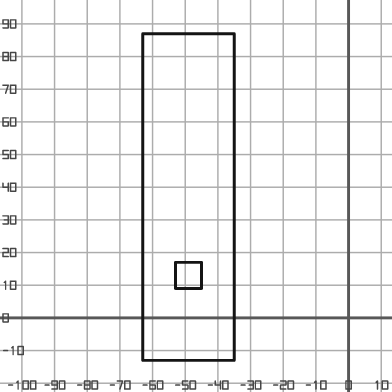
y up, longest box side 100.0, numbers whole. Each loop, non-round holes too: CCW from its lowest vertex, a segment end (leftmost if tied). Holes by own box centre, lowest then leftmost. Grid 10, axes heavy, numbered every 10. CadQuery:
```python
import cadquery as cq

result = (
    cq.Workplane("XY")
    .moveTo(-63.0, -13.0)
    .lineTo(-35.0, -13.0)
    .lineTo(-35.0, 87.0)
    .lineTo(-63.0, 87.0)
    .close()
    .moveTo(-53.0, 9.0)
    .lineTo(-45.0, 9.0)
    .lineTo(-45.0, 17.0)
    .lineTo(-53.0, 17.0)
    .close()
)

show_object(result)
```